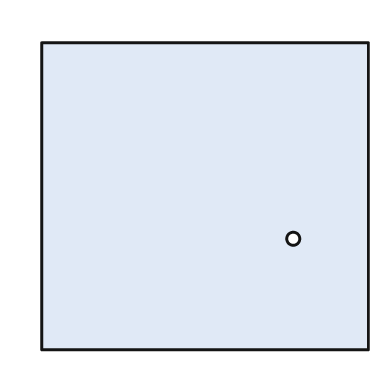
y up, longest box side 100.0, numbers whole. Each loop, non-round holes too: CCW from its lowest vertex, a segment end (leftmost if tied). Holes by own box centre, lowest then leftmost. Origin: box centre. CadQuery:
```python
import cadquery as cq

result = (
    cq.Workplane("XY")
    .moveTo(-50.0, -47.0)
    .lineTo(50.0, -47.0)
    .lineTo(50.0, 47.0)
    .lineTo(-50.0, 47.0)
    .close()
    .moveTo(27.0, -13.0)
    .circle(2.0)
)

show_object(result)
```